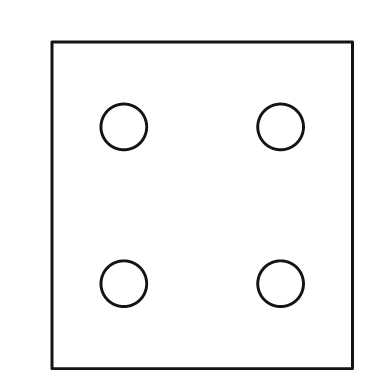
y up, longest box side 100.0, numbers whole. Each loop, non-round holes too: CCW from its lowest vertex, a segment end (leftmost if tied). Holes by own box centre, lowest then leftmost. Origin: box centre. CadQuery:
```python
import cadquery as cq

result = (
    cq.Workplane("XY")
    .moveTo(-46.0, -50.0)
    .lineTo(46.0, -50.0)
    .lineTo(46.0, 50.0)
    .lineTo(-46.0, 50.0)
    .close()
    .moveTo(-24.0, -24.0)
    .circle(7.0)
    .moveTo(24.0, -24.0)
    .circle(7.0)
    .moveTo(-24.0, 24.0)
    .circle(7.0)
    .moveTo(24.0, 24.0)
    .circle(7.0)
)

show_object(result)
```